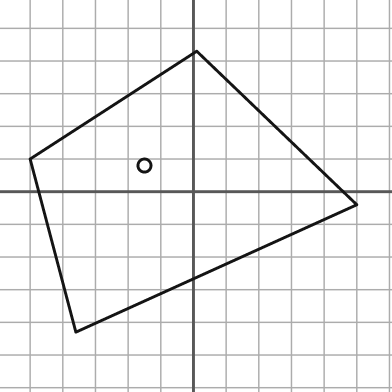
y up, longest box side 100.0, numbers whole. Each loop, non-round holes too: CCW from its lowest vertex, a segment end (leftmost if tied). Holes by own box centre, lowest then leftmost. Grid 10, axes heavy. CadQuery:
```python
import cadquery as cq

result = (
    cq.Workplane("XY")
    .moveTo(-36.0, -43.0)
    .lineTo(50.0, -4.0)
    .lineTo(1.0, 43.0)
    .lineTo(-50.0, 10.0)
    .close()
    .moveTo(-15.0, 8.0)
    .circle(2.0)
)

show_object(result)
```